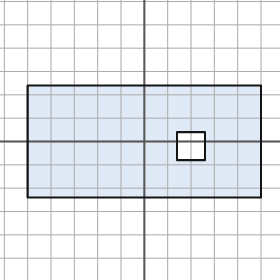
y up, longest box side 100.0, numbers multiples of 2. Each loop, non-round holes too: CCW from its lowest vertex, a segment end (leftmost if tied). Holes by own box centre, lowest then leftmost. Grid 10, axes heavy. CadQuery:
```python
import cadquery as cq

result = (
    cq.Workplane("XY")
    .moveTo(-50.0, -24.0)
    .lineTo(50.0, -24.0)
    .lineTo(50.0, 24.0)
    .lineTo(-50.0, 24.0)
    .close()
    .moveTo(14.0, -8.0)
    .lineTo(26.0, -8.0)
    .lineTo(26.0, 4.0)
    .lineTo(14.0, 4.0)
    .close()
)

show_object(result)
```